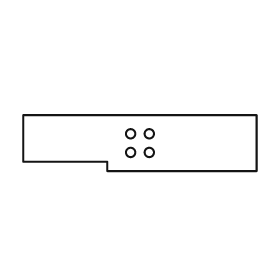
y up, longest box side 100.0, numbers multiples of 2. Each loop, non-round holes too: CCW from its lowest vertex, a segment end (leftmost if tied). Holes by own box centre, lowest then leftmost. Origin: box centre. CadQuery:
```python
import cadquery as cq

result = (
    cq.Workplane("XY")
    .moveTo(-14.0, -12.0)
    .lineTo(50.0, -12.0)
    .lineTo(50.0, 12.0)
    .lineTo(-50.0, 12.0)
    .lineTo(-50.0, -8.0)
    .lineTo(-14.0, -8.0)
    .close()
    .moveTo(-4.0, -4.0)
    .circle(2.0)
    .moveTo(4.0, -4.0)
    .circle(2.0)
    .moveTo(-4.0, 4.0)
    .circle(2.0)
    .moveTo(4.0, 4.0)
    .circle(2.0)
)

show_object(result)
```